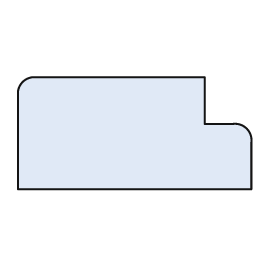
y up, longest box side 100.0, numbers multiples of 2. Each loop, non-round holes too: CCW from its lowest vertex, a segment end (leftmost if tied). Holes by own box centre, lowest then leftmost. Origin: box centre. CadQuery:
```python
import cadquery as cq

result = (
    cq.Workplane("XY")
    .moveTo(-50.0, -24.0)
    .lineTo(50.0, -24.0)
    .lineTo(50.0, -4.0)
    .threePointArc((48.0, 2.0), (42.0, 4.0))
    .lineTo(30.0, 4.0)
    .lineTo(30.0, 24.0)
    .lineTo(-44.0, 24.0)
    .threePointArc((-48.0, 22.0), (-50.0, 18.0))
    .close()
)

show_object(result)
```